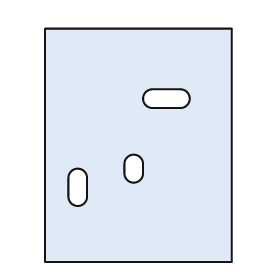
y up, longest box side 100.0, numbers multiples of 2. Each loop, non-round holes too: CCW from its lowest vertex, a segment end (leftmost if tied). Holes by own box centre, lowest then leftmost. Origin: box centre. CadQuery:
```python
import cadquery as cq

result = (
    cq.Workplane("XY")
    .moveTo(-40.0, -50.0)
    .lineTo(40.0, -50.0)
    .lineTo(40.0, 50.0)
    .lineTo(-40.0, 50.0)
    .close()
    .moveTo(-30.0, -22.0)
    .threePointArc((-26.0, -26.0), (-22.0, -22.0))
    .lineTo(-22.0, -14.0)
    .threePointArc((-26.0, -10.0), (-30.0, -14.0))
    .close()
    .moveTo(-6.0, -12.0)
    .threePointArc((-2.0, -16.0), (2.0, -12.0))
    .lineTo(2.0, -8.0)
    .threePointArc((-2.0, -4.0), (-6.0, -8.0))
    .close()
    .moveTo(6.0, 16.0)
    .lineTo(18.0, 16.0)
    .threePointArc((22.0, 20.0), (18.0, 24.0))
    .lineTo(6.0, 24.0)
    .threePointArc((2.0, 20.0), (6.0, 16.0))
    .close()
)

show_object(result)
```